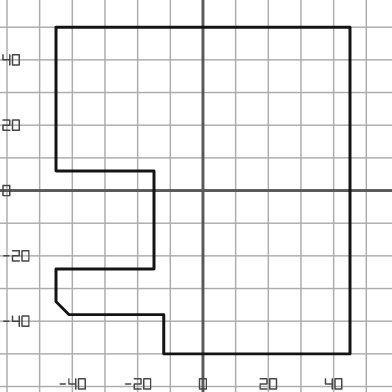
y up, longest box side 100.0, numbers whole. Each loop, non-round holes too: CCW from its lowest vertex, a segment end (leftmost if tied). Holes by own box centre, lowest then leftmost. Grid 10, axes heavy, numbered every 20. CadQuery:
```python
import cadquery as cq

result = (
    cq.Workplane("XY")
    .moveTo(-12.0, -50.0)
    .lineTo(45.0, -50.0)
    .lineTo(45.0, 50.0)
    .lineTo(-45.0, 50.0)
    .lineTo(-45.0, 6.0)
    .lineTo(-15.0, 6.0)
    .lineTo(-15.0, -24.0)
    .lineTo(-45.0, -24.0)
    .lineTo(-45.0, -34.0)
    .lineTo(-41.0, -38.0)
    .lineTo(-12.0, -38.0)
    .close()
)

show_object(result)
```